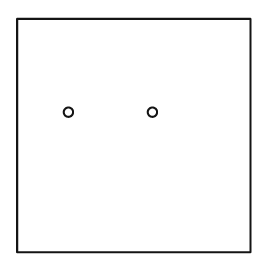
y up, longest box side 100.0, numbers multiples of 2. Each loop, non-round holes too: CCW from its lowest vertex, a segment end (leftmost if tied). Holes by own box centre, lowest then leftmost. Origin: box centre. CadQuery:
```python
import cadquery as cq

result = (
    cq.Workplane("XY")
    .moveTo(-50.0, -50.0)
    .lineTo(50.0, -50.0)
    .lineTo(50.0, 50.0)
    .lineTo(-50.0, 50.0)
    .close()
    .moveTo(-28.0, 10.0)
    .circle(2.0)
    .moveTo(8.0, 10.0)
    .circle(2.0)
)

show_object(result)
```